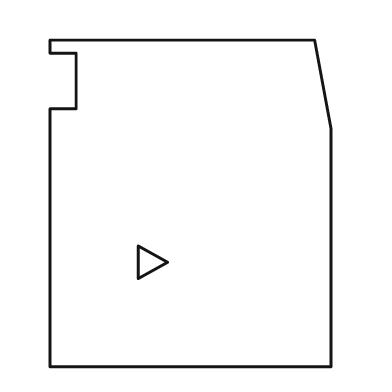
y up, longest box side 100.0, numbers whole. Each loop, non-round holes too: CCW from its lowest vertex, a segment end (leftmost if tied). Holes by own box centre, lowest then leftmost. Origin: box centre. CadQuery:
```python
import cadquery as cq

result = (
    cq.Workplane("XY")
    .moveTo(-43.0, -50.0)
    .lineTo(43.0, -50.0)
    .lineTo(43.0, 23.0)
    .lineTo(38.0, 50.0)
    .lineTo(-43.0, 50.0)
    .lineTo(-43.0, 46.0)
    .lineTo(-35.0, 46.0)
    .lineTo(-35.0, 29.0)
    .lineTo(-43.0, 29.0)
    .close()
    .moveTo(-16.0, -23.0)
    .lineTo(-7.0, -18.0)
    .lineTo(-16.0, -13.0)
    .close()
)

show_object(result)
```